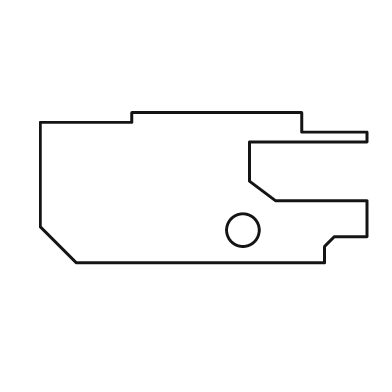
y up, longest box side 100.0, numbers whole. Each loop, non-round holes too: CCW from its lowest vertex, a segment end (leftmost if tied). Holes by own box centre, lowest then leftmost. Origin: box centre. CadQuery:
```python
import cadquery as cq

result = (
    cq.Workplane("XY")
    .moveTo(-39.0, -23.0)
    .lineTo(37.0, -23.0)
    .lineTo(37.0, -18.0)
    .lineTo(40.0, -15.0)
    .lineTo(50.0, -15.0)
    .lineTo(50.0, -4.0)
    .lineTo(22.0, -4.0)
    .lineTo(14.0, 2.0)
    .lineTo(14.0, 14.0)
    .lineTo(50.0, 14.0)
    .lineTo(50.0, 17.0)
    .lineTo(30.0, 17.0)
    .lineTo(30.0, 23.0)
    .lineTo(-22.0, 23.0)
    .lineTo(-22.0, 20.0)
    .lineTo(-50.0, 20.0)
    .lineTo(-50.0, -12.0)
    .close()
    .moveTo(12.0, -13.0)
    .circle(5.0)
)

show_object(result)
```